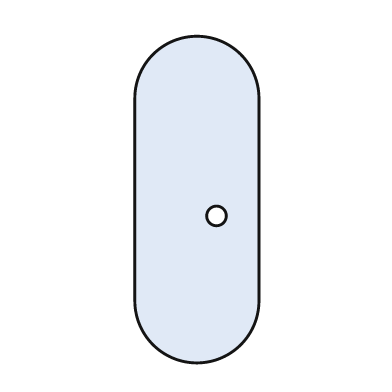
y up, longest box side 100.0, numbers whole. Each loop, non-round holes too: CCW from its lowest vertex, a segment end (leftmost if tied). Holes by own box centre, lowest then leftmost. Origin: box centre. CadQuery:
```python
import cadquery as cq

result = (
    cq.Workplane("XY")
    .moveTo(-19.0, -31.0)
    .threePointArc((0.0, -50.0), (19.0, -31.0))
    .lineTo(19.0, 31.0)
    .threePointArc((0.0, 50.0), (-19.0, 31.0))
    .close()
    .moveTo(6.0, -5.0)
    .circle(3.0)
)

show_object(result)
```